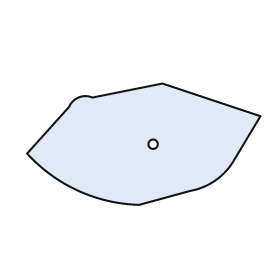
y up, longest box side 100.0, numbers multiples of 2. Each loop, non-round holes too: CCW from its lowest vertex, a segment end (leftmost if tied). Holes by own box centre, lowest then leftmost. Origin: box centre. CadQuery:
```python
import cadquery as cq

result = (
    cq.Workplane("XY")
    .moveTo(-2.0, -26.0)
    .lineTo(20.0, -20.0)
    .threePointArc((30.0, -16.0), (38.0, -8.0))
    .lineTo(50.0, 12.0)
    .lineTo(8.0, 26.0)
    .lineTo(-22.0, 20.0)
    .threePointArc((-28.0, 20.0), (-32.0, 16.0))
    .lineTo(-50.0, -4.0)
    .threePointArc((-28.0, -20.0), (-2.0, -26.0))
    .close()
    .moveTo(4.0, 0.0)
    .circle(2.0)
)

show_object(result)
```